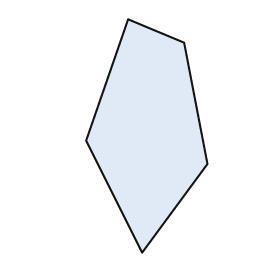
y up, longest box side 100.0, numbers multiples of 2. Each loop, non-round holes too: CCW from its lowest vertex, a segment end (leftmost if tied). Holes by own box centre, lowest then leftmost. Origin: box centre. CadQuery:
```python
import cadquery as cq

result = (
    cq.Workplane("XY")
    .moveTo(-2.0, -50.0)
    .lineTo(26.0, -12.0)
    .lineTo(16.0, 40.0)
    .lineTo(-8.0, 50.0)
    .lineTo(-26.0, -2.0)
    .close()
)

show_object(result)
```